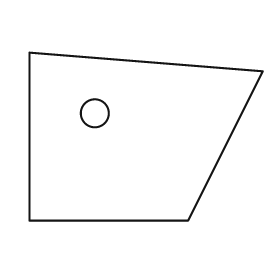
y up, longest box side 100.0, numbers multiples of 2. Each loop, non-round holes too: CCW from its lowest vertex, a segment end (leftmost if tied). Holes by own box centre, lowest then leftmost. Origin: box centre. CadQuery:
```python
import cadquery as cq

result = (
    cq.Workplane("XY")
    .moveTo(-50.0, -36.0)
    .lineTo(18.0, -36.0)
    .lineTo(50.0, 28.0)
    .lineTo(-50.0, 36.0)
    .close()
    .moveTo(-22.0, 10.0)
    .circle(6.0)
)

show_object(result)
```